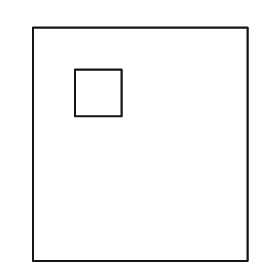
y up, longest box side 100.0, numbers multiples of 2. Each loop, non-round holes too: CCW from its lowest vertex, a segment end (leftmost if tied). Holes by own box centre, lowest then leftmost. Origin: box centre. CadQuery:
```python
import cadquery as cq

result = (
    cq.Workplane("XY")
    .moveTo(-46.0, -50.0)
    .lineTo(46.0, -50.0)
    .lineTo(46.0, 50.0)
    .lineTo(-46.0, 50.0)
    .close()
    .moveTo(-28.0, 12.0)
    .lineTo(-8.0, 12.0)
    .lineTo(-8.0, 32.0)
    .lineTo(-28.0, 32.0)
    .close()
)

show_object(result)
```